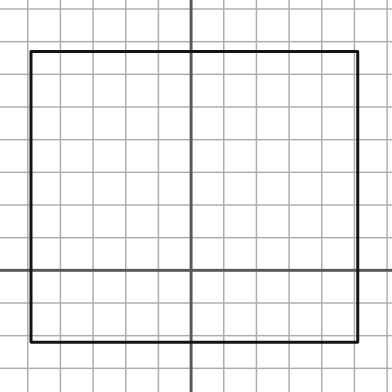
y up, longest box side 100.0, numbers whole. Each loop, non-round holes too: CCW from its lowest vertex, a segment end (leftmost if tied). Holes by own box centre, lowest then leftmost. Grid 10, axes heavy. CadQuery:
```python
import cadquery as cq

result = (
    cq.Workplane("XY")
    .moveTo(-49.0, -22.0)
    .lineTo(51.0, -22.0)
    .lineTo(51.0, 67.0)
    .lineTo(-49.0, 67.0)
    .close()
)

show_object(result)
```